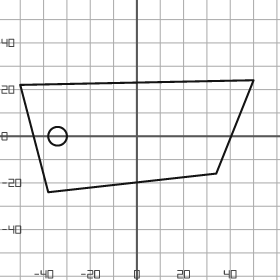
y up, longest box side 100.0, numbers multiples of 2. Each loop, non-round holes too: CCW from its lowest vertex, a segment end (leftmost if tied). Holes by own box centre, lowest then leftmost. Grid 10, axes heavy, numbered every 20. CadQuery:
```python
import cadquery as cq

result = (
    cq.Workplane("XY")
    .moveTo(-38.0, -24.0)
    .lineTo(34.0, -16.0)
    .lineTo(50.0, 24.0)
    .lineTo(-50.0, 22.0)
    .close()
    .moveTo(-34.0, 0.0)
    .circle(4.0)
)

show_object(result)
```